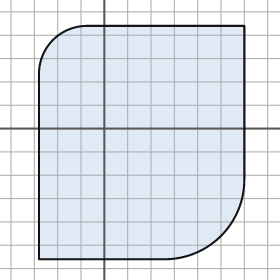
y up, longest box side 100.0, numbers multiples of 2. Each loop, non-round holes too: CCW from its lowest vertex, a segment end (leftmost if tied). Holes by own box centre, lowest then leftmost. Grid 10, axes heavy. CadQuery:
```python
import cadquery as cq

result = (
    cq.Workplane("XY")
    .moveTo(-28.0, -56.0)
    .lineTo(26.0, -56.0)
    .threePointArc((50.0, -46.0), (60.0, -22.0))
    .lineTo(60.0, 44.0)
    .lineTo(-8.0, 44.0)
    .threePointArc((-22.0, 38.0), (-28.0, 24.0))
    .close()
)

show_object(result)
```